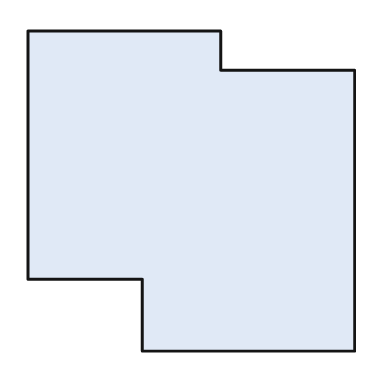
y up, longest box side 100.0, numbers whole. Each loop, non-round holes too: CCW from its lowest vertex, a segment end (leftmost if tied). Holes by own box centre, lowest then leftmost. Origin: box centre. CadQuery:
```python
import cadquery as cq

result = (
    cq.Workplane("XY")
    .moveTo(-15.0, -49.0)
    .lineTo(50.0, -49.0)
    .lineTo(50.0, 37.0)
    .lineTo(9.0, 37.0)
    .lineTo(9.0, 49.0)
    .lineTo(-50.0, 49.0)
    .lineTo(-50.0, -27.0)
    .lineTo(-15.0, -27.0)
    .close()
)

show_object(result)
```